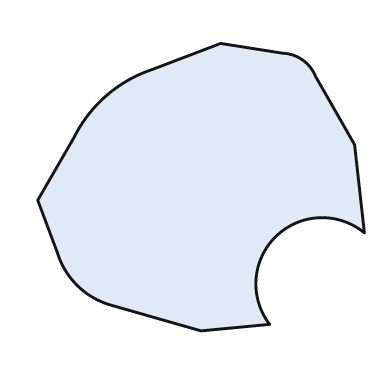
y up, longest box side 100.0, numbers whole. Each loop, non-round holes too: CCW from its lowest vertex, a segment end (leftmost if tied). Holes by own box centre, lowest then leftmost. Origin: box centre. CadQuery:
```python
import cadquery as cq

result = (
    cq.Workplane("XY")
    .moveTo(0.0, -44.0)
    .lineTo(21.0, -42.0)
    .threePointArc((23.0, -15.0), (50.0, -14.0))
    .lineTo(47.0, 13.0)
    .lineTo(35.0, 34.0)
    .threePointArc((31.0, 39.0), (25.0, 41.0))
    .lineTo(6.0, 44.0)
    .lineTo(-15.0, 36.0)
    .threePointArc((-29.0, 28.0), (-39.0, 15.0))
    .lineTo(-50.0, -4.0)
    .lineTo(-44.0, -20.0)
    .threePointArc((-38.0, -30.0), (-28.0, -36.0))
    .close()
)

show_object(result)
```